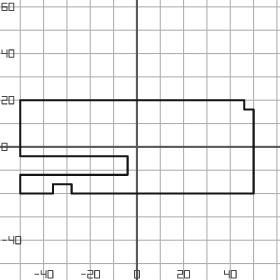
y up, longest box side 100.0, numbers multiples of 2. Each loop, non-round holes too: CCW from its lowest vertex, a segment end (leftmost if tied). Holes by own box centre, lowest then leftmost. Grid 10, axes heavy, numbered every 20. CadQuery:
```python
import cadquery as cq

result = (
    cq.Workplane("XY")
    .moveTo(-50.0, -20.0)
    .lineTo(-36.0, -20.0)
    .lineTo(-36.0, -16.0)
    .lineTo(-28.0, -16.0)
    .lineTo(-28.0, -20.0)
    .lineTo(50.0, -20.0)
    .lineTo(50.0, 16.0)
    .lineTo(46.0, 16.0)
    .lineTo(46.0, 20.0)
    .lineTo(-50.0, 20.0)
    .lineTo(-50.0, -4.0)
    .lineTo(-4.0, -4.0)
    .lineTo(-4.0, -12.0)
    .lineTo(-50.0, -12.0)
    .close()
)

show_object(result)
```